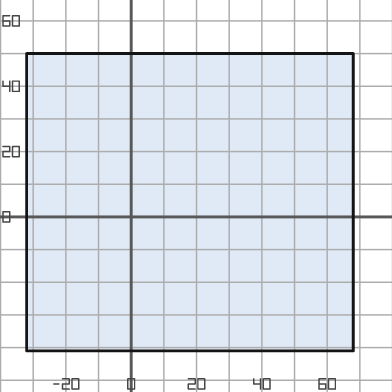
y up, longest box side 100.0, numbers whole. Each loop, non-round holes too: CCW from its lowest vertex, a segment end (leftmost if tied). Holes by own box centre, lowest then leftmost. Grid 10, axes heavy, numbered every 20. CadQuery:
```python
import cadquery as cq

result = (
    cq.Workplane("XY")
    .moveTo(-32.0, -41.0)
    .lineTo(68.0, -41.0)
    .lineTo(68.0, 50.0)
    .lineTo(-32.0, 50.0)
    .close()
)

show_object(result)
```